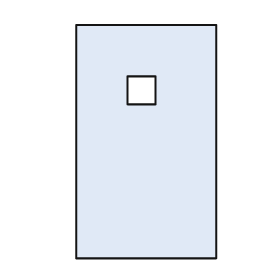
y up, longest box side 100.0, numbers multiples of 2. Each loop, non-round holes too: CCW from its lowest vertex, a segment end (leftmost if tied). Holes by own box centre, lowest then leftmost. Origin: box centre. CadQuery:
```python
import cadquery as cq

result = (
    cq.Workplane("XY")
    .moveTo(-30.0, -50.0)
    .lineTo(30.0, -50.0)
    .lineTo(30.0, 50.0)
    .lineTo(-30.0, 50.0)
    .close()
    .moveTo(-8.0, 16.0)
    .lineTo(4.0, 16.0)
    .lineTo(4.0, 28.0)
    .lineTo(-8.0, 28.0)
    .close()
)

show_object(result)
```